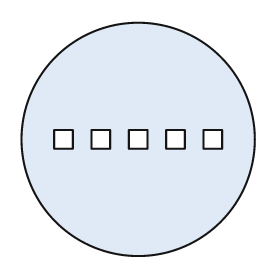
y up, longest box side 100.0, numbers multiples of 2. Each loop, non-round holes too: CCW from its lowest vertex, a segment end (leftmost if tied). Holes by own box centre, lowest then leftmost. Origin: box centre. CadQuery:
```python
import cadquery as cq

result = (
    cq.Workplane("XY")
    .moveTo(0.0, 0.0)
    .circle(50.0)
    .moveTo(-36.0, -4.0)
    .lineTo(-28.0, -4.0)
    .lineTo(-28.0, 4.0)
    .lineTo(-36.0, 4.0)
    .close()
    .moveTo(-20.0, -4.0)
    .lineTo(-12.0, -4.0)
    .lineTo(-12.0, 4.0)
    .lineTo(-20.0, 4.0)
    .close()
    .moveTo(-4.0, -4.0)
    .lineTo(4.0, -4.0)
    .lineTo(4.0, 4.0)
    .lineTo(-4.0, 4.0)
    .close()
    .moveTo(12.0, -4.0)
    .lineTo(20.0, -4.0)
    .lineTo(20.0, 4.0)
    .lineTo(12.0, 4.0)
    .close()
    .moveTo(28.0, -4.0)
    .lineTo(36.0, -4.0)
    .lineTo(36.0, 4.0)
    .lineTo(28.0, 4.0)
    .close()
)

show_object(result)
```